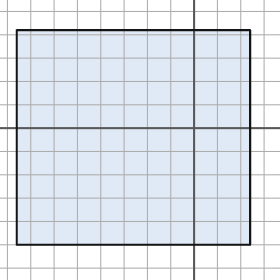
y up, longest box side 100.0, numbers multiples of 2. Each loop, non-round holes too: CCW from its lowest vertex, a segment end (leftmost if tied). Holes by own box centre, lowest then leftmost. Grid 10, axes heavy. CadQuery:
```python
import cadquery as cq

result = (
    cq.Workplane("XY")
    .moveTo(-76.0, -50.0)
    .lineTo(24.0, -50.0)
    .lineTo(24.0, 42.0)
    .lineTo(-76.0, 42.0)
    .close()
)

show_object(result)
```